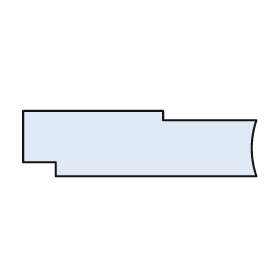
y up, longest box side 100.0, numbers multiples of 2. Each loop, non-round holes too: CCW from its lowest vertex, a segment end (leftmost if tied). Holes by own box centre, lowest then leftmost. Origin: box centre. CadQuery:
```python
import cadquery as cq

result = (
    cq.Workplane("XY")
    .moveTo(-36.0, -14.0)
    .lineTo(50.0, -14.0)
    .threePointArc((48.0, -2.0), (50.0, 10.0))
    .lineTo(10.0, 10.0)
    .lineTo(10.0, 14.0)
    .lineTo(-50.0, 14.0)
    .lineTo(-50.0, -8.0)
    .lineTo(-36.0, -8.0)
    .close()
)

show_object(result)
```